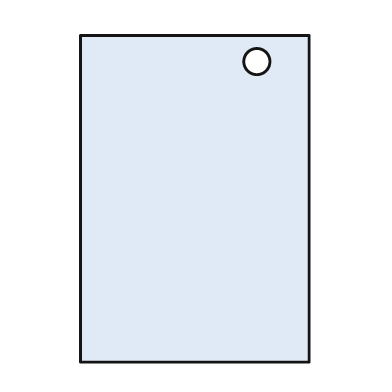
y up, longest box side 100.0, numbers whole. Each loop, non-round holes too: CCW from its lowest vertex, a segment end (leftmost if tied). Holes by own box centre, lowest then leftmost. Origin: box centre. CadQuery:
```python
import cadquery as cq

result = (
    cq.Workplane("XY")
    .moveTo(-35.0, -50.0)
    .lineTo(35.0, -50.0)
    .lineTo(35.0, 50.0)
    .lineTo(-35.0, 50.0)
    .close()
    .moveTo(19.0, 42.0)
    .circle(4.0)
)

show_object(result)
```